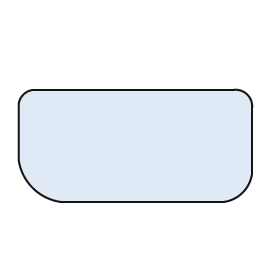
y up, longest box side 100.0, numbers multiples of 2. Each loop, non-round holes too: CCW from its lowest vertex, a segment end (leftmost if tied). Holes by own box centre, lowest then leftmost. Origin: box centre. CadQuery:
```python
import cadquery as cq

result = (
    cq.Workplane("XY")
    .moveTo(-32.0, -24.0)
    .lineTo(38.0, -24.0)
    .threePointArc((46.0, -20.0), (50.0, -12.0))
    .lineTo(50.0, 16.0)
    .threePointArc((48.0, 22.0), (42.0, 24.0))
    .lineTo(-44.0, 24.0)
    .threePointArc((-48.0, 22.0), (-50.0, 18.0))
    .lineTo(-50.0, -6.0)
    .threePointArc((-44.0, -18.0), (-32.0, -24.0))
    .close()
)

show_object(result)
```